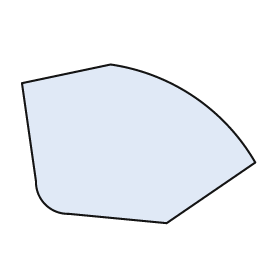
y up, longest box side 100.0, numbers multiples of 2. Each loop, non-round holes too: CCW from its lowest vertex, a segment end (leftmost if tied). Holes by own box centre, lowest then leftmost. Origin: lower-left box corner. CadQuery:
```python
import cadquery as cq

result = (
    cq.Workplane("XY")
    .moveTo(62.0, 0.0)
    .lineTo(100.0, 26.0)
    .threePointArc((74.0, 54.0), (38.0, 68.0))
    .lineTo(0.0, 60.0)
    .lineTo(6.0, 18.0)
    .threePointArc((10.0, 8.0), (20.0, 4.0))
    .close()
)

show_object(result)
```